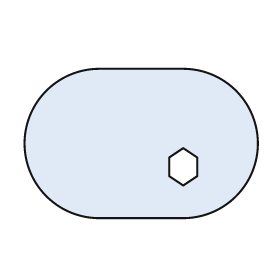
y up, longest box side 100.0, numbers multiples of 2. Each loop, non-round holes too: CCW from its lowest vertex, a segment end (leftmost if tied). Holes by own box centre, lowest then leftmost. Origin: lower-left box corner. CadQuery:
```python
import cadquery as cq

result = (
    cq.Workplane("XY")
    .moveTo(32.0, 0.0)
    .lineTo(68.0, 0.0)
    .threePointArc((100.0, 32.0), (68.0, 64.0))
    .lineTo(32.0, 64.0)
    .threePointArc((0.0, 32.0), (32.0, 0.0))
    .close()
    .moveTo(68.0, 14.0)
    .lineTo(74.0, 18.0)
    .lineTo(74.0, 26.0)
    .lineTo(68.0, 30.0)
    .lineTo(62.0, 26.0)
    .lineTo(62.0, 18.0)
    .close()
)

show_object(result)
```